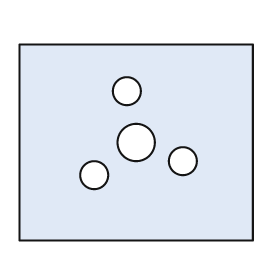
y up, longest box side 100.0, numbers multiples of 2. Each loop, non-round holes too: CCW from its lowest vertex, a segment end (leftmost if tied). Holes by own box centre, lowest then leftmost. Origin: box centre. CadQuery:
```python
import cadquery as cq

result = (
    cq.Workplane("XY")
    .moveTo(-50.0, -42.0)
    .lineTo(50.0, -42.0)
    .lineTo(50.0, 42.0)
    .lineTo(-50.0, 42.0)
    .close()
    .moveTo(-18.0, -14.0)
    .circle(6.0)
    .moveTo(20.0, -8.0)
    .circle(6.0)
    .moveTo(0.0, 0.0)
    .circle(8.0)
    .moveTo(-4.0, 22.0)
    .circle(6.0)
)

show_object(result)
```